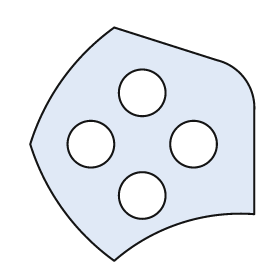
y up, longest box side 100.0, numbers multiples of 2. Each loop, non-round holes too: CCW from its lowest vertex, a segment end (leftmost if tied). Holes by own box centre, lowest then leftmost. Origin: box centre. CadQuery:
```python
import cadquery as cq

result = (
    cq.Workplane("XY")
    .moveTo(-12.0, -50.0)
    .threePointArc((16.0, -34.0), (48.0, -30.0))
    .lineTo(48.0, 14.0)
    .threePointArc((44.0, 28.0), (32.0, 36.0))
    .lineTo(-12.0, 50.0)
    .threePointArc((-34.0, 28.0), (-48.0, 0.0))
    .threePointArc((-34.0, -28.0), (-12.0, -50.0))
    .close()
    .moveTo(0.0, -22.0)
    .circle(10.0)
    .moveTo(-22.0, 0.0)
    .circle(10.0)
    .moveTo(22.0, 0.0)
    .circle(10.0)
    .moveTo(0.0, 22.0)
    .circle(10.0)
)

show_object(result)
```